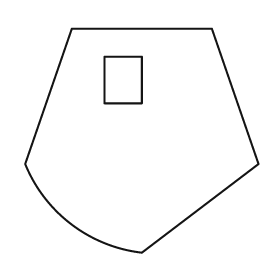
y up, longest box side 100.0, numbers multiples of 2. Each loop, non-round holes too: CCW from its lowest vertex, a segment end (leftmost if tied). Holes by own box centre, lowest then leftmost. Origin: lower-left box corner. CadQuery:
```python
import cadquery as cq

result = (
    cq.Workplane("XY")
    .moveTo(50.0, 0.0)
    .lineTo(100.0, 38.0)
    .lineTo(80.0, 96.0)
    .lineTo(20.0, 96.0)
    .lineTo(0.0, 38.0)
    .threePointArc((20.0, 12.0), (50.0, 0.0))
    .close()
    .moveTo(34.0, 64.0)
    .lineTo(50.0, 64.0)
    .lineTo(50.0, 84.0)
    .lineTo(34.0, 84.0)
    .close()
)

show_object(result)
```